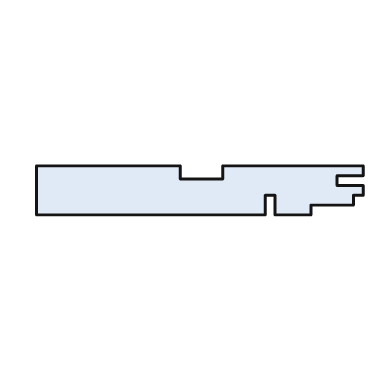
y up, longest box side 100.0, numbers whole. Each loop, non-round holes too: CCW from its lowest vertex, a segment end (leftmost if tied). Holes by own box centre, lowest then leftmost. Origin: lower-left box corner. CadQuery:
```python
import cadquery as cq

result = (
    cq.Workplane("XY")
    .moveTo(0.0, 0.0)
    .lineTo(70.0, 0.0)
    .lineTo(70.0, 6.0)
    .lineTo(73.0, 6.0)
    .lineTo(73.0, 0.0)
    .lineTo(84.0, 0.0)
    .lineTo(84.0, 3.0)
    .lineTo(97.0, 3.0)
    .lineTo(97.0, 6.0)
    .lineTo(100.0, 6.0)
    .lineTo(100.0, 9.0)
    .lineTo(92.0, 9.0)
    .lineTo(92.0, 12.0)
    .lineTo(100.0, 12.0)
    .lineTo(100.0, 15.0)
    .lineTo(57.0, 15.0)
    .lineTo(57.0, 11.0)
    .lineTo(44.0, 11.0)
    .lineTo(44.0, 15.0)
    .lineTo(0.0, 15.0)
    .close()
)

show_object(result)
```